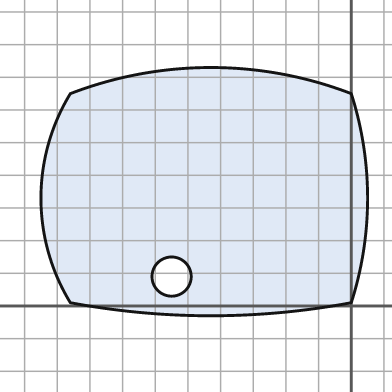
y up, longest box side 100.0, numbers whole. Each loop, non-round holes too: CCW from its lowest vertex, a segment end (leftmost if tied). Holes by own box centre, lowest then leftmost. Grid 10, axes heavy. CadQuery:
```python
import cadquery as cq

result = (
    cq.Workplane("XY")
    .moveTo(-86.0, 1.0)
    .threePointArc((-43.0, -3.0), (0.0, 1.0))
    .threePointArc((5.0, 33.0), (0.0, 65.0))
    .threePointArc((-43.0, 73.0), (-86.0, 65.0))
    .threePointArc((-95.0, 33.0), (-86.0, 1.0))
    .close()
    .moveTo(-55.0, 9.0)
    .circle(6.0)
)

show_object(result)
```